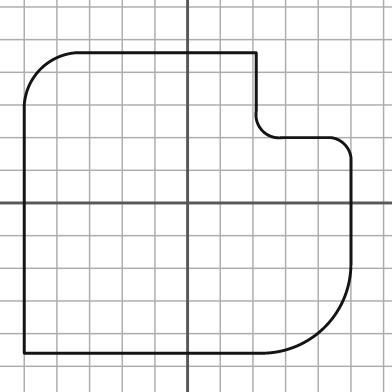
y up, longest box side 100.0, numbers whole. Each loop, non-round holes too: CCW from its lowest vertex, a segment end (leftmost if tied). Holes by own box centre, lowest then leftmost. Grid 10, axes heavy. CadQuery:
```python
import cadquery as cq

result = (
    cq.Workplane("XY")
    .moveTo(-50.0, -46.0)
    .lineTo(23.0, -46.0)
    .threePointArc((42.0, -38.0), (50.0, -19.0))
    .lineTo(50.0, 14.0)
    .threePointArc((48.0, 18.0), (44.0, 20.0))
    .lineTo(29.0, 20.0)
    .threePointArc((23.0, 22.0), (21.0, 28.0))
    .lineTo(21.0, 46.0)
    .lineTo(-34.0, 46.0)
    .threePointArc((-45.0, 41.0), (-50.0, 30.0))
    .close()
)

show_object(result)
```